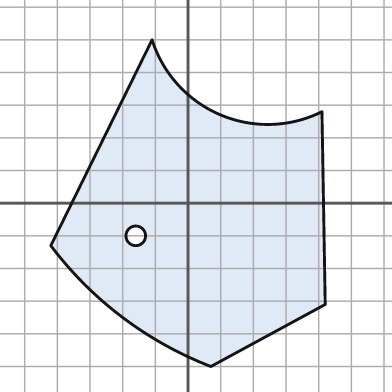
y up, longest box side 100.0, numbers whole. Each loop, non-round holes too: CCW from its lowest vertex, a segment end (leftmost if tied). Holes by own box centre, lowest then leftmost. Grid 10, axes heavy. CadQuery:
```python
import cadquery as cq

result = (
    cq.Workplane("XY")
    .moveTo(7.0, -50.0)
    .lineTo(42.0, -31.0)
    .lineTo(41.0, 28.0)
    .threePointArc((10.0, 27.0), (-11.0, 50.0))
    .lineTo(-42.0, -13.0)
    .threePointArc((-20.0, -35.0), (7.0, -50.0))
    .close()
    .moveTo(-16.0, -10.0)
    .circle(3.0)
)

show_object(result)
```